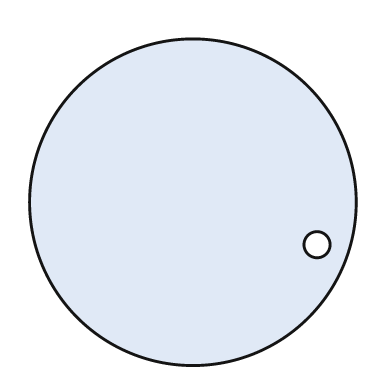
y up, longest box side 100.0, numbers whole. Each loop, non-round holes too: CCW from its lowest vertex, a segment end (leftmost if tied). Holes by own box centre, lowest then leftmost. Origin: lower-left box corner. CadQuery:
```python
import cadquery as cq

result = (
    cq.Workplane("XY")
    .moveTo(50.0, 50.0)
    .circle(50.0)
    .moveTo(88.0, 37.0)
    .circle(4.0)
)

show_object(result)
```